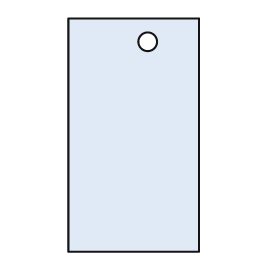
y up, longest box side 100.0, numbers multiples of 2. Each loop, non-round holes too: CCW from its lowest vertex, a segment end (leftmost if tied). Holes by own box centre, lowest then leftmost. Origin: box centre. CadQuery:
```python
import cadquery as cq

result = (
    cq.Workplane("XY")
    .moveTo(-28.0, -50.0)
    .lineTo(28.0, -50.0)
    .lineTo(28.0, 50.0)
    .lineTo(-28.0, 50.0)
    .close()
    .moveTo(6.0, 40.0)
    .circle(4.0)
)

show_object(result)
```